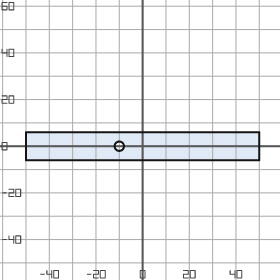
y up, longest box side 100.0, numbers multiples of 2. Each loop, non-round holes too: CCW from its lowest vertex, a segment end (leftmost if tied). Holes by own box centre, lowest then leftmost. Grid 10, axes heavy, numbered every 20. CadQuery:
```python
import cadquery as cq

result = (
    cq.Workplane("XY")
    .moveTo(-50.0, -6.0)
    .lineTo(50.0, -6.0)
    .lineTo(50.0, 6.0)
    .lineTo(-50.0, 6.0)
    .close()
    .moveTo(-10.0, 0.0)
    .circle(2.0)
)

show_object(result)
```